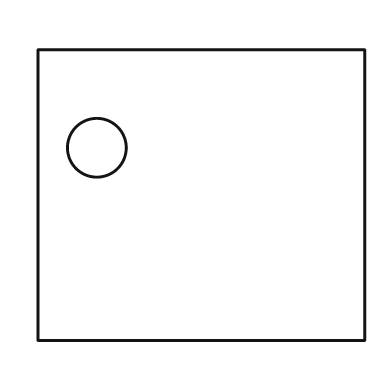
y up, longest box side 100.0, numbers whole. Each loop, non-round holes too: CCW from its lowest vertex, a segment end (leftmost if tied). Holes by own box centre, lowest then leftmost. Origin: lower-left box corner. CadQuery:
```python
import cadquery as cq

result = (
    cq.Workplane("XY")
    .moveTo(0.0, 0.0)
    .lineTo(100.0, 0.0)
    .lineTo(100.0, 89.0)
    .lineTo(0.0, 89.0)
    .close()
    .moveTo(18.0, 59.0)
    .circle(9.0)
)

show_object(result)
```